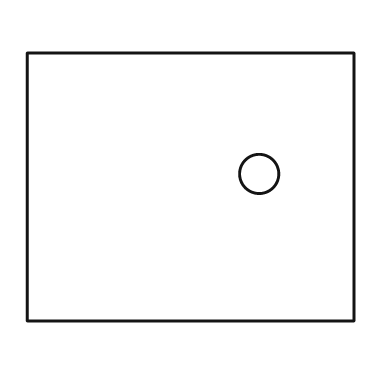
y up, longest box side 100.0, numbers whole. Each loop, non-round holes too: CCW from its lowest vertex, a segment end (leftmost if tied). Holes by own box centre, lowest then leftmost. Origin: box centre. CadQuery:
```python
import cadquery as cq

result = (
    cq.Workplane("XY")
    .moveTo(-50.0, -41.0)
    .lineTo(50.0, -41.0)
    .lineTo(50.0, 41.0)
    .lineTo(-50.0, 41.0)
    .close()
    .moveTo(21.0, 4.0)
    .circle(6.0)
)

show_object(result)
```